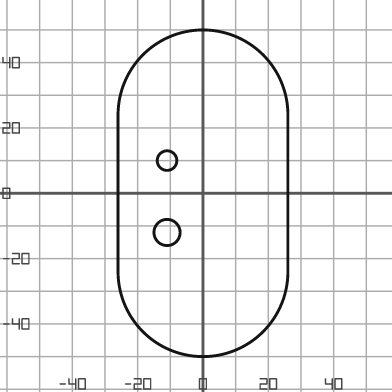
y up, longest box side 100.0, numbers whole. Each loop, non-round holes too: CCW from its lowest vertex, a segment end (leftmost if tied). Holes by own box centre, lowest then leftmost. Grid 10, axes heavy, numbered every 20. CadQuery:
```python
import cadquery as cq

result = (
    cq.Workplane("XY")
    .moveTo(-26.0, -24.0)
    .threePointArc((0.0, -50.0), (26.0, -24.0))
    .lineTo(26.0, 24.0)
    .threePointArc((0.0, 50.0), (-26.0, 24.0))
    .close()
    .moveTo(-11.0, -12.0)
    .circle(4.0)
    .moveTo(-11.0, 10.0)
    .circle(3.0)
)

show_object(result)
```